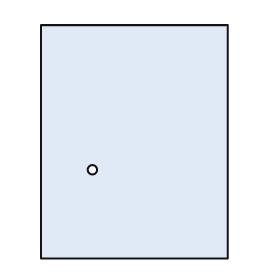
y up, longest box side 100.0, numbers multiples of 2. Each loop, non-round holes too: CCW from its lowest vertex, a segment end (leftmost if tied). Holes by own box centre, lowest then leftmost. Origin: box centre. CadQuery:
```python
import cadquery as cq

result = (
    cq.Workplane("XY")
    .moveTo(-40.0, -50.0)
    .lineTo(40.0, -50.0)
    .lineTo(40.0, 50.0)
    .lineTo(-40.0, 50.0)
    .close()
    .moveTo(-18.0, -12.0)
    .circle(2.0)
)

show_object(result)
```